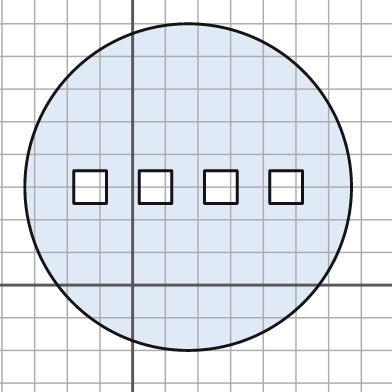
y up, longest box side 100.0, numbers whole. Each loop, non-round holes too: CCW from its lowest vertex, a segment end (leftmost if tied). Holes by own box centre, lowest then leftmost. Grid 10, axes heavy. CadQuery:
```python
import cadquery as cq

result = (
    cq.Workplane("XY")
    .moveTo(17.0, 30.0)
    .circle(50.0)
    .moveTo(-18.0, 25.0)
    .lineTo(-8.0, 25.0)
    .lineTo(-8.0, 35.0)
    .lineTo(-18.0, 35.0)
    .close()
    .moveTo(2.0, 25.0)
    .lineTo(12.0, 25.0)
    .lineTo(12.0, 35.0)
    .lineTo(2.0, 35.0)
    .close()
    .moveTo(22.0, 25.0)
    .lineTo(32.0, 25.0)
    .lineTo(32.0, 35.0)
    .lineTo(22.0, 35.0)
    .close()
    .moveTo(42.0, 25.0)
    .lineTo(52.0, 25.0)
    .lineTo(52.0, 35.0)
    .lineTo(42.0, 35.0)
    .close()
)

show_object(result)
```